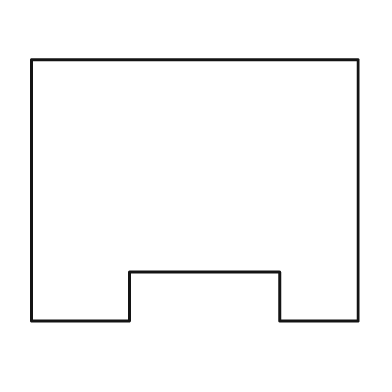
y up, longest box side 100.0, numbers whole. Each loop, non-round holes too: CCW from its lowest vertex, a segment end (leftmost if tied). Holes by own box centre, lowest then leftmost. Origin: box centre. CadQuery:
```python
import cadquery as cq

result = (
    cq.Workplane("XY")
    .moveTo(-50.0, -40.0)
    .lineTo(-20.0, -40.0)
    .lineTo(-20.0, -25.0)
    .lineTo(26.0, -25.0)
    .lineTo(26.0, -40.0)
    .lineTo(50.0, -40.0)
    .lineTo(50.0, 40.0)
    .lineTo(-50.0, 40.0)
    .close()
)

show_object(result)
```